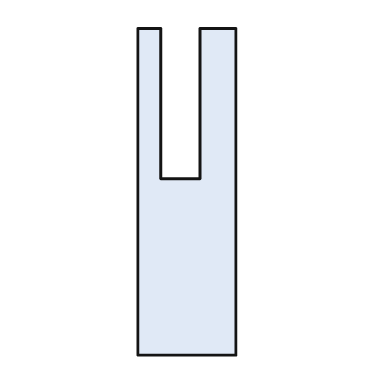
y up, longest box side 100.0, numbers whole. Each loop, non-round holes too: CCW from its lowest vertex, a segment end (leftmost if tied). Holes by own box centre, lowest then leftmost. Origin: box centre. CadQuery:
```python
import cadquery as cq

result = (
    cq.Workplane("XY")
    .moveTo(-15.0, -50.0)
    .lineTo(15.0, -50.0)
    .lineTo(15.0, 50.0)
    .lineTo(4.0, 50.0)
    .lineTo(4.0, 4.0)
    .lineTo(-8.0, 4.0)
    .lineTo(-8.0, 50.0)
    .lineTo(-15.0, 50.0)
    .close()
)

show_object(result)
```